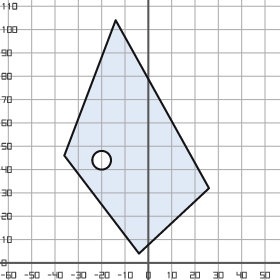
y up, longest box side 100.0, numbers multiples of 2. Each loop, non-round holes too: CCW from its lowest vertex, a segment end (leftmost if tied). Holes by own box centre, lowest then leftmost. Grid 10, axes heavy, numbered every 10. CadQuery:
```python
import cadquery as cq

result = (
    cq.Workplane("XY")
    .moveTo(-4.0, 4.0)
    .lineTo(26.0, 32.0)
    .lineTo(-14.0, 104.0)
    .lineTo(-36.0, 46.0)
    .close()
    .moveTo(-20.0, 44.0)
    .circle(4.0)
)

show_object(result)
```